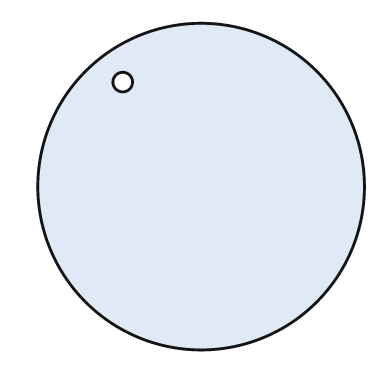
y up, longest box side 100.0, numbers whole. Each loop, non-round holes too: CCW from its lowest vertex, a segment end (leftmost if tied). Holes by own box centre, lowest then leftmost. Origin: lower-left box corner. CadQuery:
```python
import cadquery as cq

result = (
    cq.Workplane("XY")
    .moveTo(50.0, 50.0)
    .circle(50.0)
    .moveTo(26.0, 82.0)
    .circle(3.0)
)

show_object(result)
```